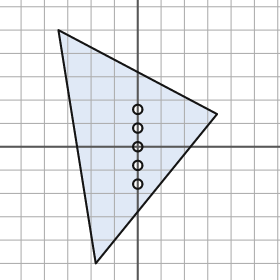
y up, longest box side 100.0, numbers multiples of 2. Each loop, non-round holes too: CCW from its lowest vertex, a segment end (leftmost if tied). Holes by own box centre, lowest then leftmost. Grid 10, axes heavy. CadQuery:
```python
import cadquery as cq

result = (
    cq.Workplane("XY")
    .moveTo(-18.0, -50.0)
    .lineTo(34.0, 14.0)
    .lineTo(-34.0, 50.0)
    .close()
    .moveTo(0.0, -16.0)
    .circle(2.0)
    .moveTo(0.0, -8.0)
    .circle(2.0)
    .moveTo(0.0, 0.0)
    .circle(2.0)
    .moveTo(0.0, 8.0)
    .circle(2.0)
    .moveTo(0.0, 16.0)
    .circle(2.0)
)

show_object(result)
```